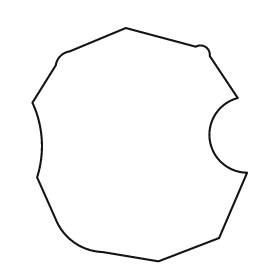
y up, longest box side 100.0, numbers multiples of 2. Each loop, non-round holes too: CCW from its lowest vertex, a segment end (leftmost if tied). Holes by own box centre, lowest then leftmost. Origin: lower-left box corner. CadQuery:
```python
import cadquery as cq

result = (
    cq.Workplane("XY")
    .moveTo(54.0, 0.0)
    .lineTo(80.0, 10.0)
    .lineTo(92.0, 38.0)
    .threePointArc((76.0, 52.0), (88.0, 70.0))
    .lineTo(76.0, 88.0)
    .threePointArc((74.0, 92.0), (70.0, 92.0))
    .lineTo(40.0, 100.0)
    .lineTo(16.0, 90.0)
    .threePointArc((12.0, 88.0), (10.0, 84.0))
    .lineTo(0.0, 68.0)
    .threePointArc((4.0, 52.0), (2.0, 36.0))
    .lineTo(10.0, 18.0)
    .threePointArc((18.0, 8.0), (30.0, 4.0))
    .close()
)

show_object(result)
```